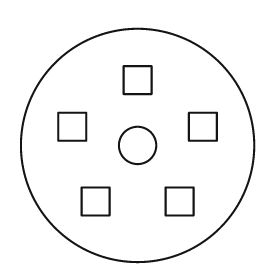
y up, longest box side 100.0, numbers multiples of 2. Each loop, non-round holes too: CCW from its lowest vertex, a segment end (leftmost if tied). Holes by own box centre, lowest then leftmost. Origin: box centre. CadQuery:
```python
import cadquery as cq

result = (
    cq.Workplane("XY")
    .moveTo(0.0, 0.0)
    .circle(50.0)
    .moveTo(-24.0, -30.0)
    .lineTo(-12.0, -30.0)
    .lineTo(-12.0, -18.0)
    .lineTo(-24.0, -18.0)
    .close()
    .moveTo(12.0, -30.0)
    .lineTo(24.0, -30.0)
    .lineTo(24.0, -18.0)
    .lineTo(12.0, -18.0)
    .close()
    .moveTo(0.0, 0.0)
    .circle(8.0)
    .moveTo(-34.0, 2.0)
    .lineTo(-22.0, 2.0)
    .lineTo(-22.0, 14.0)
    .lineTo(-34.0, 14.0)
    .close()
    .moveTo(22.0, 2.0)
    .lineTo(34.0, 2.0)
    .lineTo(34.0, 14.0)
    .lineTo(22.0, 14.0)
    .close()
    .moveTo(-6.0, 22.0)
    .lineTo(6.0, 22.0)
    .lineTo(6.0, 34.0)
    .lineTo(-6.0, 34.0)
    .close()
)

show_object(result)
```